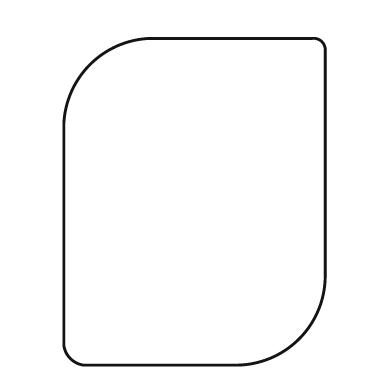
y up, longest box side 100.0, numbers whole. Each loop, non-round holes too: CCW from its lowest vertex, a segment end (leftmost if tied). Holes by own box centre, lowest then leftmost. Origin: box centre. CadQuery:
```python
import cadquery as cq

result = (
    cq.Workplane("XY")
    .moveTo(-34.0, -50.0)
    .lineTo(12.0, -50.0)
    .threePointArc((32.0, -42.0), (40.0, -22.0))
    .lineTo(40.0, 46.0)
    .threePointArc((39.0, 49.0), (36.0, 50.0))
    .lineTo(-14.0, 50.0)
    .threePointArc((-32.0, 42.0), (-40.0, 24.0))
    .lineTo(-40.0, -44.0)
    .threePointArc((-38.0, -48.0), (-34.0, -50.0))
    .close()
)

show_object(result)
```